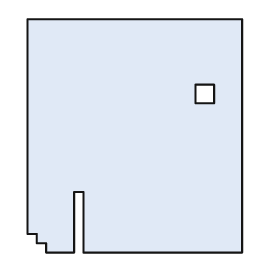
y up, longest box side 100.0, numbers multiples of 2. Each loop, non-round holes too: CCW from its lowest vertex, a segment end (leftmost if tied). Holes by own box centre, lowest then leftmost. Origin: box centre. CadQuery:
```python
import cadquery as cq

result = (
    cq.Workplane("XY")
    .moveTo(-38.0, -50.0)
    .lineTo(-26.0, -50.0)
    .lineTo(-26.0, -24.0)
    .lineTo(-22.0, -24.0)
    .lineTo(-22.0, -50.0)
    .lineTo(46.0, -50.0)
    .lineTo(46.0, 50.0)
    .lineTo(-46.0, 50.0)
    .lineTo(-46.0, -42.0)
    .lineTo(-42.0, -42.0)
    .lineTo(-42.0, -46.0)
    .lineTo(-38.0, -46.0)
    .close()
    .moveTo(26.0, 14.0)
    .lineTo(34.0, 14.0)
    .lineTo(34.0, 22.0)
    .lineTo(26.0, 22.0)
    .close()
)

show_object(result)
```